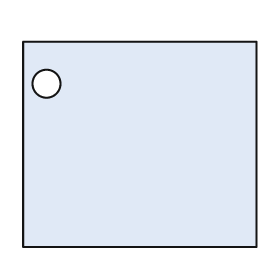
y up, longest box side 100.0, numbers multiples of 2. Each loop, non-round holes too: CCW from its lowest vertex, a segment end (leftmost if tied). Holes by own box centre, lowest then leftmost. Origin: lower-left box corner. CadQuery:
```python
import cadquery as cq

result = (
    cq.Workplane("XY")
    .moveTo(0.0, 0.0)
    .lineTo(100.0, 0.0)
    .lineTo(100.0, 88.0)
    .lineTo(0.0, 88.0)
    .close()
    .moveTo(10.0, 70.0)
    .circle(6.0)
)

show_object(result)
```